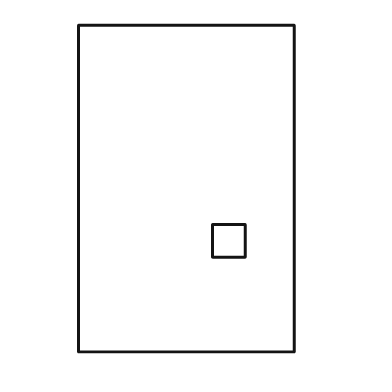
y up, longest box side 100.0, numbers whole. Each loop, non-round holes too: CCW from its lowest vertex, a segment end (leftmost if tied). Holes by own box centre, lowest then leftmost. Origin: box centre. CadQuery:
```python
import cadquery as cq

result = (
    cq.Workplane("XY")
    .moveTo(-33.0, -50.0)
    .lineTo(33.0, -50.0)
    .lineTo(33.0, 50.0)
    .lineTo(-33.0, 50.0)
    .close()
    .moveTo(8.0, -21.0)
    .lineTo(18.0, -21.0)
    .lineTo(18.0, -11.0)
    .lineTo(8.0, -11.0)
    .close()
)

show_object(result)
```